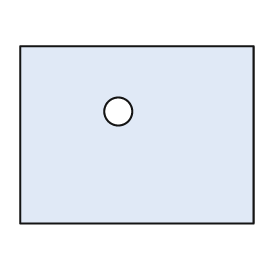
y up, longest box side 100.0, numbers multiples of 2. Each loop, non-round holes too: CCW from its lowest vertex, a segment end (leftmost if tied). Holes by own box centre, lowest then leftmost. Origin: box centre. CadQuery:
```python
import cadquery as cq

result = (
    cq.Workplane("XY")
    .moveTo(-50.0, -38.0)
    .lineTo(50.0, -38.0)
    .lineTo(50.0, 38.0)
    .lineTo(-50.0, 38.0)
    .close()
    .moveTo(-8.0, 10.0)
    .circle(6.0)
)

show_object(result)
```